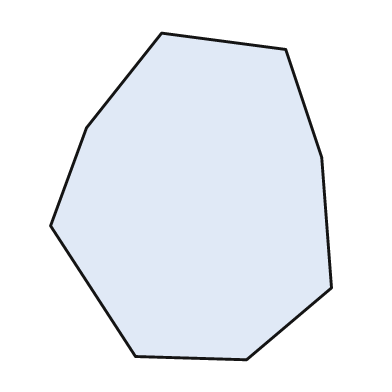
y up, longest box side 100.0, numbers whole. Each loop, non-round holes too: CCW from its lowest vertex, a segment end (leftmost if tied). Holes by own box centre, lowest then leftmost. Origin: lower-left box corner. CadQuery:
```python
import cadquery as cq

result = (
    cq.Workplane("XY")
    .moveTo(60.0, 0.0)
    .lineTo(86.0, 22.0)
    .lineTo(83.0, 62.0)
    .lineTo(72.0, 95.0)
    .lineTo(34.0, 100.0)
    .lineTo(11.0, 71.0)
    .lineTo(0.0, 41.0)
    .lineTo(26.0, 1.0)
    .close()
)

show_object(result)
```